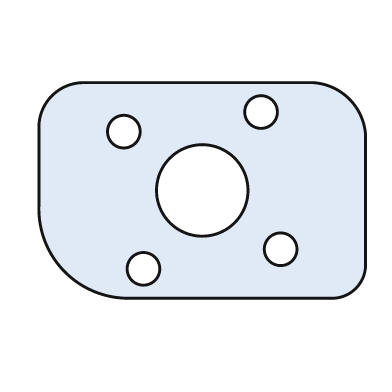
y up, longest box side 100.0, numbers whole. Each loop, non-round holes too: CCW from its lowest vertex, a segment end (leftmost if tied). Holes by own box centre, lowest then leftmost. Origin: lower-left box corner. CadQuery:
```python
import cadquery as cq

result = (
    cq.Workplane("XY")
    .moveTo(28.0, 0.0)
    .lineTo(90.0, 0.0)
    .threePointArc((97.0, 3.0), (100.0, 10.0))
    .lineTo(100.0, 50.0)
    .threePointArc((95.0, 61.0), (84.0, 66.0))
    .lineTo(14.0, 66.0)
    .threePointArc((4.0, 62.0), (0.0, 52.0))
    .lineTo(0.0, 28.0)
    .threePointArc((8.0, 8.0), (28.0, 0.0))
    .close()
    .moveTo(32.0, 9.0)
    .circle(5.0)
    .moveTo(74.0, 15.0)
    .circle(5.0)
    .moveTo(50.0, 33.0)
    .circle(14.0)
    .moveTo(26.0, 51.0)
    .circle(5.0)
    .moveTo(68.0, 57.0)
    .circle(5.0)
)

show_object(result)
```